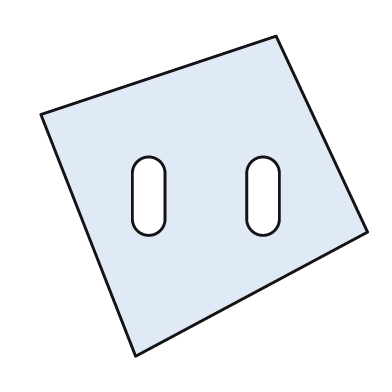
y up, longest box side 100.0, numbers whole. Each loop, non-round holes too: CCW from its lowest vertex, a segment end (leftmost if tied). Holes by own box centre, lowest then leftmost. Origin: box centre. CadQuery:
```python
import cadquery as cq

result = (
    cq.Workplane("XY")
    .moveTo(-21.0, -49.0)
    .lineTo(50.0, -11.0)
    .lineTo(22.0, 49.0)
    .lineTo(-50.0, 25.0)
    .close()
    .moveTo(-22.0, -7.0)
    .threePointArc((-17.0, -12.0), (-12.0, -7.0))
    .lineTo(-12.0, 7.0)
    .threePointArc((-17.0, 12.0), (-22.0, 7.0))
    .close()
    .moveTo(13.0, -7.0)
    .threePointArc((18.0, -12.0), (23.0, -7.0))
    .lineTo(23.0, 7.0)
    .threePointArc((18.0, 12.0), (13.0, 7.0))
    .close()
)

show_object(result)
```